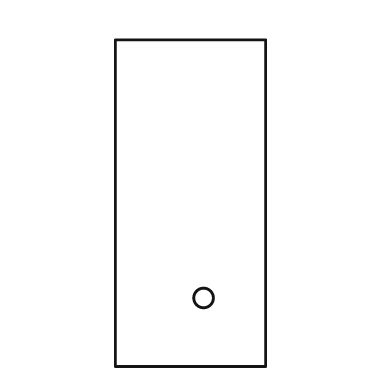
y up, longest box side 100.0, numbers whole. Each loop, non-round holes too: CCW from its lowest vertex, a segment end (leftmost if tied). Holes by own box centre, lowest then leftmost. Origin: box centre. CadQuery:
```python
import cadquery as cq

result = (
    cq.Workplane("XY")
    .moveTo(-23.0, -50.0)
    .lineTo(23.0, -50.0)
    .lineTo(23.0, 50.0)
    .lineTo(-23.0, 50.0)
    .close()
    .moveTo(4.0, -29.0)
    .circle(3.0)
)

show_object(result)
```